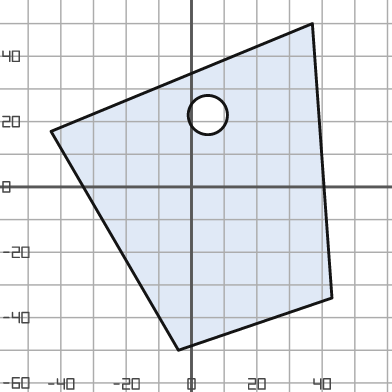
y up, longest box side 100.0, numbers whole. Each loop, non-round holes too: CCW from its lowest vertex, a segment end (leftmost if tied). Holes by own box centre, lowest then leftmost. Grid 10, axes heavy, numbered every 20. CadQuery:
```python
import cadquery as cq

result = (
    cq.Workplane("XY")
    .moveTo(-4.0, -50.0)
    .lineTo(43.0, -34.0)
    .lineTo(37.0, 50.0)
    .lineTo(-43.0, 17.0)
    .close()
    .moveTo(5.0, 22.0)
    .circle(6.0)
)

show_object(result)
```